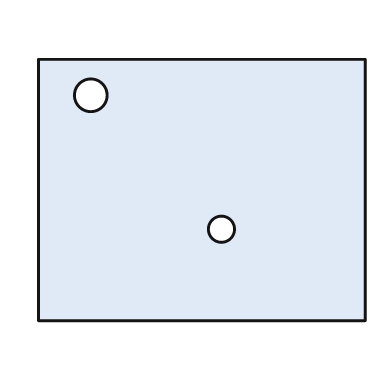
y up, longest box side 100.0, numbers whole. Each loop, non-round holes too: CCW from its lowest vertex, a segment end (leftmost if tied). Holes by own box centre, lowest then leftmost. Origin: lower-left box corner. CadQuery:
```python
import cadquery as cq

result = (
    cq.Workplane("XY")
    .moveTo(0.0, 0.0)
    .lineTo(100.0, 0.0)
    .lineTo(100.0, 80.0)
    .lineTo(0.0, 80.0)
    .close()
    .moveTo(56.0, 28.0)
    .circle(4.0)
    .moveTo(16.0, 69.0)
    .circle(5.0)
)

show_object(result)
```